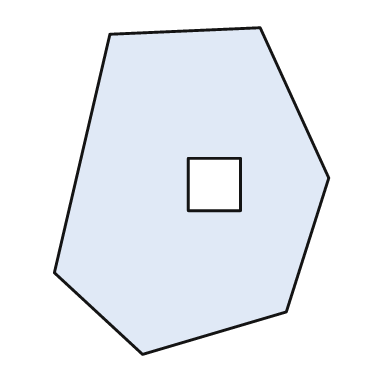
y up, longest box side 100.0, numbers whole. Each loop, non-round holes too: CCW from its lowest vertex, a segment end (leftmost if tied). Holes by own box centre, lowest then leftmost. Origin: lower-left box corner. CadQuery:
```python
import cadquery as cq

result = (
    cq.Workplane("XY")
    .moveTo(27.0, 0.0)
    .lineTo(71.0, 13.0)
    .lineTo(84.0, 54.0)
    .lineTo(63.0, 100.0)
    .lineTo(17.0, 98.0)
    .lineTo(0.0, 25.0)
    .close()
    .moveTo(41.0, 44.0)
    .lineTo(57.0, 44.0)
    .lineTo(57.0, 60.0)
    .lineTo(41.0, 60.0)
    .close()
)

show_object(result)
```